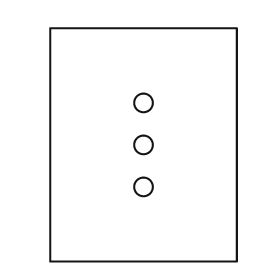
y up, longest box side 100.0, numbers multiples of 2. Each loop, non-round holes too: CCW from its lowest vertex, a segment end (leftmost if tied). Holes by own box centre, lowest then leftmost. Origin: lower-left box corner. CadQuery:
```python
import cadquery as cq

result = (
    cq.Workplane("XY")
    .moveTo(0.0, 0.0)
    .lineTo(80.0, 0.0)
    .lineTo(80.0, 100.0)
    .lineTo(0.0, 100.0)
    .close()
    .moveTo(40.0, 32.0)
    .circle(4.0)
    .moveTo(40.0, 50.0)
    .circle(4.0)
    .moveTo(40.0, 68.0)
    .circle(4.0)
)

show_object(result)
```